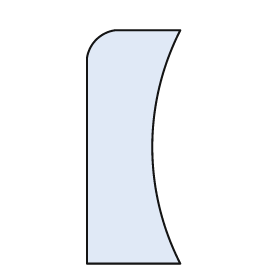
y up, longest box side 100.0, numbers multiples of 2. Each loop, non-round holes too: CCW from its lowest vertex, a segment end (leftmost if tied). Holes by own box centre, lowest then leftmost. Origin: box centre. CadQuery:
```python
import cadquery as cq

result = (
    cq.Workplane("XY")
    .moveTo(-20.0, -50.0)
    .lineTo(20.0, -50.0)
    .threePointArc((8.0, 0.0), (20.0, 50.0))
    .lineTo(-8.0, 50.0)
    .threePointArc((-16.0, 46.0), (-20.0, 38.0))
    .close()
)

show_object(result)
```